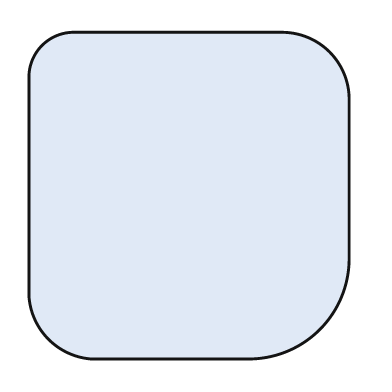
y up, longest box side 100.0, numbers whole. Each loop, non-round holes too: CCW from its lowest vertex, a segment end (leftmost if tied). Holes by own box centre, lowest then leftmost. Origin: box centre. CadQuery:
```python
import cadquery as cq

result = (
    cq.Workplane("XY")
    .moveTo(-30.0, -50.0)
    .lineTo(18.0, -50.0)
    .threePointArc((40.0, -41.0), (49.0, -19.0))
    .lineTo(49.0, 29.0)
    .threePointArc((43.0, 44.0), (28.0, 50.0))
    .lineTo(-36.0, 50.0)
    .threePointArc((-45.0, 46.0), (-49.0, 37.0))
    .lineTo(-49.0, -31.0)
    .threePointArc((-43.0, -44.0), (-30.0, -50.0))
    .close()
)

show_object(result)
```